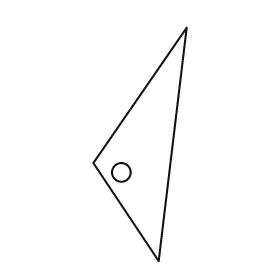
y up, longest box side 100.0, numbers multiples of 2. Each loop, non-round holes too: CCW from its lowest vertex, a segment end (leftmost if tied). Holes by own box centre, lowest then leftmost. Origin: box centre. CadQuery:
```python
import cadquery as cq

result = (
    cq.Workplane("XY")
    .moveTo(8.0, -50.0)
    .lineTo(20.0, 50.0)
    .lineTo(-20.0, -8.0)
    .close()
    .moveTo(-8.0, -12.0)
    .circle(4.0)
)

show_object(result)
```